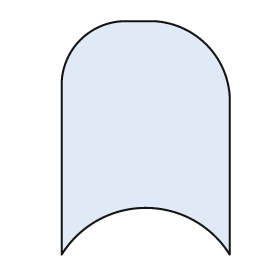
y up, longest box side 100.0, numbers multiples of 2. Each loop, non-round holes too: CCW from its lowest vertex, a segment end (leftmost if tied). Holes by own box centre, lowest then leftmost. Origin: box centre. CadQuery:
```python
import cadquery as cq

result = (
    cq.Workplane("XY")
    .moveTo(-36.0, -50.0)
    .threePointArc((0.0, -30.0), (36.0, -50.0))
    .lineTo(36.0, 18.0)
    .threePointArc((26.0, 40.0), (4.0, 50.0))
    .lineTo(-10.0, 50.0)
    .threePointArc((-28.0, 42.0), (-36.0, 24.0))
    .close()
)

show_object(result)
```